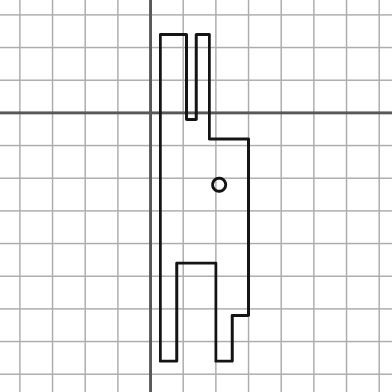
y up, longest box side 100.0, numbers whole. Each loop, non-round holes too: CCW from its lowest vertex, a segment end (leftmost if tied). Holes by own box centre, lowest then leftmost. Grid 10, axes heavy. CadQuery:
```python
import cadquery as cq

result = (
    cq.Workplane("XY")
    .moveTo(3.0, -76.0)
    .lineTo(8.0, -76.0)
    .lineTo(8.0, -46.0)
    .lineTo(20.0, -46.0)
    .lineTo(20.0, -76.0)
    .lineTo(25.0, -76.0)
    .lineTo(25.0, -62.0)
    .lineTo(30.0, -62.0)
    .lineTo(30.0, -8.0)
    .lineTo(18.0, -8.0)
    .lineTo(18.0, 24.0)
    .lineTo(14.0, 24.0)
    .lineTo(14.0, -2.0)
    .lineTo(11.0, -2.0)
    .lineTo(11.0, 24.0)
    .lineTo(3.0, 24.0)
    .close()
    .moveTo(21.0, -22.0)
    .circle(2.0)
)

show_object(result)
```